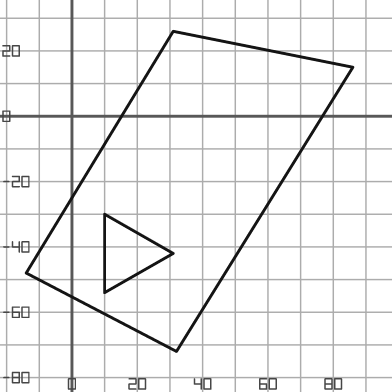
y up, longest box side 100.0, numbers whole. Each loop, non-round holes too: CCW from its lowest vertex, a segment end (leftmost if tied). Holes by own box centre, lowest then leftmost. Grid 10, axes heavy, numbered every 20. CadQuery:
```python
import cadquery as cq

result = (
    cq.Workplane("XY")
    .moveTo(32.0, -72.0)
    .lineTo(86.0, 15.0)
    .lineTo(31.0, 26.0)
    .lineTo(-14.0, -48.0)
    .close()
    .moveTo(10.0, -54.0)
    .lineTo(31.0, -42.0)
    .lineTo(10.0, -30.0)
    .close()
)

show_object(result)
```